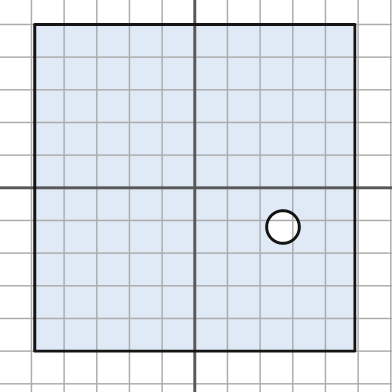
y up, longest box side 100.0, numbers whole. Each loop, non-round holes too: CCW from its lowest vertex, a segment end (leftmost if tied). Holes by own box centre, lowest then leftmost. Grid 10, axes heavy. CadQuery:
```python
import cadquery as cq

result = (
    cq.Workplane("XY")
    .moveTo(-49.0, -50.0)
    .lineTo(49.0, -50.0)
    .lineTo(49.0, 50.0)
    .lineTo(-49.0, 50.0)
    .close()
    .moveTo(27.0, -12.0)
    .circle(5.0)
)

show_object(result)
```